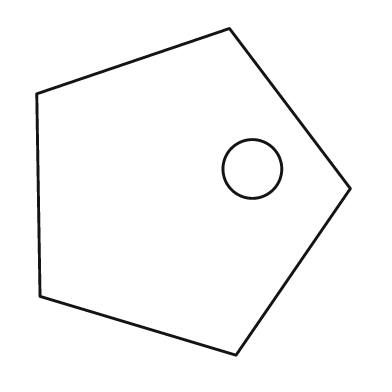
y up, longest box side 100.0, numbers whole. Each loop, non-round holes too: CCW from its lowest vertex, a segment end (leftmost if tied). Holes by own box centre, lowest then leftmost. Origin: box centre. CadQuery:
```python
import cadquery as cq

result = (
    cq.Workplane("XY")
    .moveTo(13.0, -50.0)
    .lineTo(48.0, 1.0)
    .lineTo(11.0, 50.0)
    .lineTo(-48.0, 30.0)
    .lineTo(-47.0, -32.0)
    .close()
    .moveTo(18.0, 7.0)
    .circle(9.0)
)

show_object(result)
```